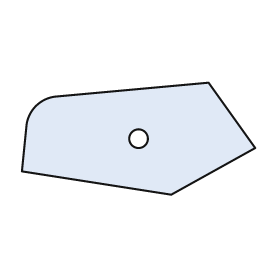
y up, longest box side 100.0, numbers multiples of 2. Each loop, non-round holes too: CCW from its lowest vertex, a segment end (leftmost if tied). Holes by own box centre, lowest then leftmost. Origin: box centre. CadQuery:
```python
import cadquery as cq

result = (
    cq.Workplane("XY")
    .moveTo(14.0, -24.0)
    .lineTo(50.0, -4.0)
    .lineTo(30.0, 24.0)
    .lineTo(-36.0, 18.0)
    .threePointArc((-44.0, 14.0), (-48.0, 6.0))
    .lineTo(-50.0, -14.0)
    .close()
    .moveTo(0.0, 0.0)
    .circle(4.0)
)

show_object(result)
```